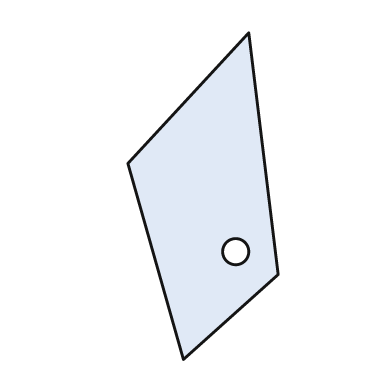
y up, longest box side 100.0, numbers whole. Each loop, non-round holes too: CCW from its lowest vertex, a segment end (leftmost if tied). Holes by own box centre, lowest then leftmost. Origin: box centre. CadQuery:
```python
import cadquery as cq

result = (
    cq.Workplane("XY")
    .moveTo(-6.0, -50.0)
    .lineTo(23.0, -24.0)
    .lineTo(14.0, 50.0)
    .lineTo(-23.0, 10.0)
    .close()
    .moveTo(10.0, -17.0)
    .circle(4.0)
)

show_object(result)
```